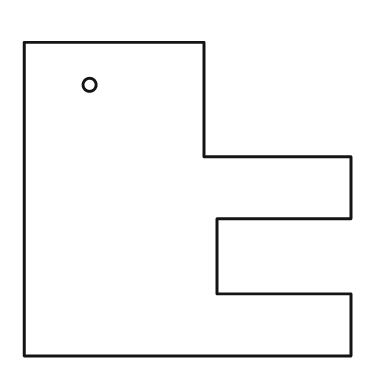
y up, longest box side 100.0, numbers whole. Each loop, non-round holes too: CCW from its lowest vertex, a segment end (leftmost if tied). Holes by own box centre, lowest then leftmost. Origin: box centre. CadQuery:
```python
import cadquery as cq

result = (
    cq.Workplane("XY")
    .moveTo(-50.0, -48.0)
    .lineTo(50.0, -48.0)
    .lineTo(50.0, -29.0)
    .lineTo(9.0, -29.0)
    .lineTo(9.0, -6.0)
    .lineTo(50.0, -6.0)
    .lineTo(50.0, 13.0)
    .lineTo(5.0, 13.0)
    .lineTo(5.0, 48.0)
    .lineTo(-50.0, 48.0)
    .close()
    .moveTo(-30.0, 35.0)
    .circle(2.0)
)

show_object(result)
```